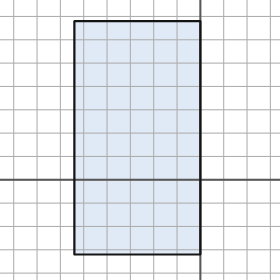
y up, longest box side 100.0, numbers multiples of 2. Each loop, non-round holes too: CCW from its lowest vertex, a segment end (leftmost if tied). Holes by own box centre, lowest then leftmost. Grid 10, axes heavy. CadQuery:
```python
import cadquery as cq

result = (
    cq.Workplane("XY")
    .moveTo(-54.0, -32.0)
    .lineTo(0.0, -32.0)
    .lineTo(0.0, 68.0)
    .lineTo(-54.0, 68.0)
    .close()
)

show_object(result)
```